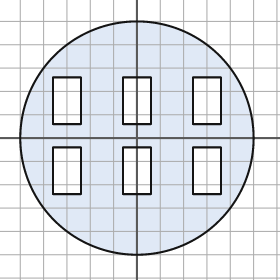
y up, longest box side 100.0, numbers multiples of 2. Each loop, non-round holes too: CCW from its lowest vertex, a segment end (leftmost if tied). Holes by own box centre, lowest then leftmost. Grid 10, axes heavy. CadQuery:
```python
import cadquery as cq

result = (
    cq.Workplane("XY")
    .moveTo(0.0, 0.0)
    .circle(50.0)
    .moveTo(-36.0, -24.0)
    .lineTo(-24.0, -24.0)
    .lineTo(-24.0, -4.0)
    .lineTo(-36.0, -4.0)
    .close()
    .moveTo(-6.0, -24.0)
    .lineTo(6.0, -24.0)
    .lineTo(6.0, -4.0)
    .lineTo(-6.0, -4.0)
    .close()
    .moveTo(24.0, -24.0)
    .lineTo(36.0, -24.0)
    .lineTo(36.0, -4.0)
    .lineTo(24.0, -4.0)
    .close()
    .moveTo(-36.0, 6.0)
    .lineTo(-24.0, 6.0)
    .lineTo(-24.0, 26.0)
    .lineTo(-36.0, 26.0)
    .close()
    .moveTo(-6.0, 6.0)
    .lineTo(6.0, 6.0)
    .lineTo(6.0, 26.0)
    .lineTo(-6.0, 26.0)
    .close()
    .moveTo(24.0, 6.0)
    .lineTo(36.0, 6.0)
    .lineTo(36.0, 26.0)
    .lineTo(24.0, 26.0)
    .close()
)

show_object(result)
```